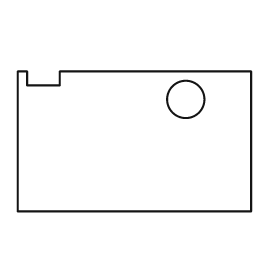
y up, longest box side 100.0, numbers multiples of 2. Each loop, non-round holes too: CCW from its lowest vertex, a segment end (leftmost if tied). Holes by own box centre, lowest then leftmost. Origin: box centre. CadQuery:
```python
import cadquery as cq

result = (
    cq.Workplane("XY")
    .moveTo(-50.0, -30.0)
    .lineTo(50.0, -30.0)
    .lineTo(50.0, 30.0)
    .lineTo(-32.0, 30.0)
    .lineTo(-32.0, 24.0)
    .lineTo(-46.0, 24.0)
    .lineTo(-46.0, 30.0)
    .lineTo(-50.0, 30.0)
    .close()
    .moveTo(22.0, 18.0)
    .circle(8.0)
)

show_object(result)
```